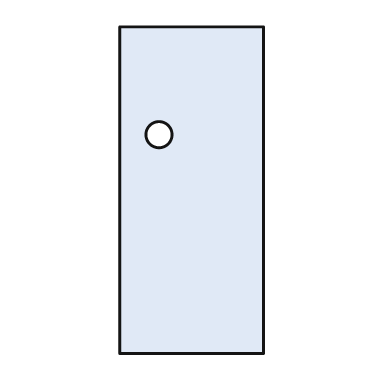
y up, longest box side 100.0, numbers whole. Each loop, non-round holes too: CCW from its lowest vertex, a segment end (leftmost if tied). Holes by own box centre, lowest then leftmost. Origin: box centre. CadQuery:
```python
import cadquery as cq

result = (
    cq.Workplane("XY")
    .moveTo(-22.0, -50.0)
    .lineTo(22.0, -50.0)
    .lineTo(22.0, 50.0)
    .lineTo(-22.0, 50.0)
    .close()
    .moveTo(-10.0, 17.0)
    .circle(4.0)
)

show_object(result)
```